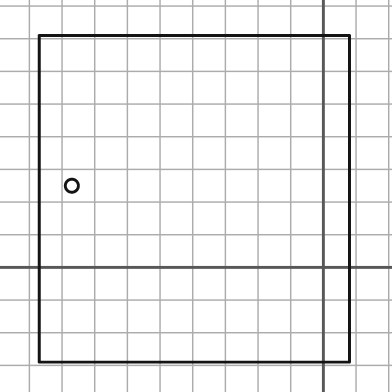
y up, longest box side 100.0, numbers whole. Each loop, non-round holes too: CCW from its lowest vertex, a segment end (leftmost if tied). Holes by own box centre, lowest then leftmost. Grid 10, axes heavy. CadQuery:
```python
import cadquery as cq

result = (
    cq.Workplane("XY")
    .moveTo(-87.0, -29.0)
    .lineTo(8.0, -29.0)
    .lineTo(8.0, 71.0)
    .lineTo(-87.0, 71.0)
    .close()
    .moveTo(-77.0, 25.0)
    .circle(2.0)
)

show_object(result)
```